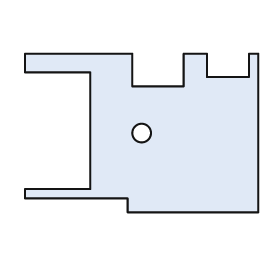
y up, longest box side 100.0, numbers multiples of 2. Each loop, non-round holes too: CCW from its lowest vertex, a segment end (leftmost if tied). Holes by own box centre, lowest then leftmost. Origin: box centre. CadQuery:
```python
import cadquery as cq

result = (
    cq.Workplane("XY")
    .moveTo(-6.0, -34.0)
    .lineTo(50.0, -34.0)
    .lineTo(50.0, 34.0)
    .lineTo(46.0, 34.0)
    .lineTo(46.0, 24.0)
    .lineTo(28.0, 24.0)
    .lineTo(28.0, 34.0)
    .lineTo(18.0, 34.0)
    .lineTo(18.0, 20.0)
    .lineTo(-4.0, 20.0)
    .lineTo(-4.0, 34.0)
    .lineTo(-50.0, 34.0)
    .lineTo(-50.0, 26.0)
    .lineTo(-22.0, 26.0)
    .lineTo(-22.0, -24.0)
    .lineTo(-50.0, -24.0)
    .lineTo(-50.0, -28.0)
    .lineTo(-6.0, -28.0)
    .close()
    .moveTo(0.0, 0.0)
    .circle(4.0)
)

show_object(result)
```